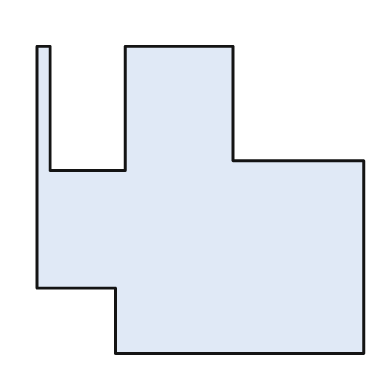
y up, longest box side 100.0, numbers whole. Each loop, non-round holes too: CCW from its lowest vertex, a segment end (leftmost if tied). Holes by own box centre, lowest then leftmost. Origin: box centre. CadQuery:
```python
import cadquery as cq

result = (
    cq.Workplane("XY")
    .moveTo(-26.0, -47.0)
    .lineTo(50.0, -47.0)
    .lineTo(50.0, 12.0)
    .lineTo(10.0, 12.0)
    .lineTo(10.0, 47.0)
    .lineTo(-23.0, 47.0)
    .lineTo(-23.0, 9.0)
    .lineTo(-46.0, 9.0)
    .lineTo(-46.0, 47.0)
    .lineTo(-50.0, 47.0)
    .lineTo(-50.0, -27.0)
    .lineTo(-26.0, -27.0)
    .close()
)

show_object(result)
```